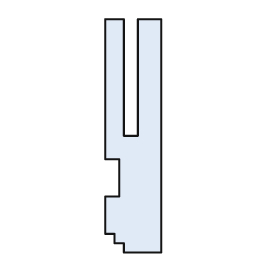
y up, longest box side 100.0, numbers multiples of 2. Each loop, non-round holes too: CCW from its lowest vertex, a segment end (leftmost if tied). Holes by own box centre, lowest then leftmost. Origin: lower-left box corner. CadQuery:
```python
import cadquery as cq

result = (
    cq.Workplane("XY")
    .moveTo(8.0, 0.0)
    .lineTo(24.0, 0.0)
    .lineTo(24.0, 100.0)
    .lineTo(14.0, 100.0)
    .lineTo(14.0, 50.0)
    .lineTo(8.0, 50.0)
    .lineTo(8.0, 100.0)
    .lineTo(0.0, 100.0)
    .lineTo(0.0, 40.0)
    .lineTo(6.0, 40.0)
    .lineTo(6.0, 24.0)
    .lineTo(0.0, 24.0)
    .lineTo(0.0, 8.0)
    .lineTo(4.0, 8.0)
    .lineTo(4.0, 4.0)
    .lineTo(8.0, 4.0)
    .close()
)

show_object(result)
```